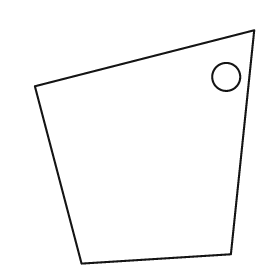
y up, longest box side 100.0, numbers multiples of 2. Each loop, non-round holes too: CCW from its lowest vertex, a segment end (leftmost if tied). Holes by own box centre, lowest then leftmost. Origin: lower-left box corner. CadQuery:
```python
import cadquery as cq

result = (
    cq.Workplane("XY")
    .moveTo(20.0, 0.0)
    .lineTo(84.0, 4.0)
    .lineTo(94.0, 100.0)
    .lineTo(0.0, 76.0)
    .close()
    .moveTo(82.0, 80.0)
    .circle(6.0)
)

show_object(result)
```